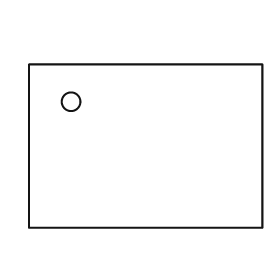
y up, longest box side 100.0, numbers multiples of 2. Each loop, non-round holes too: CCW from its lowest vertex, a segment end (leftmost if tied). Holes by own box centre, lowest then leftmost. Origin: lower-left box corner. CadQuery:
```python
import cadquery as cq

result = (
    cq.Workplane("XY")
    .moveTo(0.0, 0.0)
    .lineTo(100.0, 0.0)
    .lineTo(100.0, 70.0)
    .lineTo(0.0, 70.0)
    .close()
    .moveTo(18.0, 54.0)
    .circle(4.0)
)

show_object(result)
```